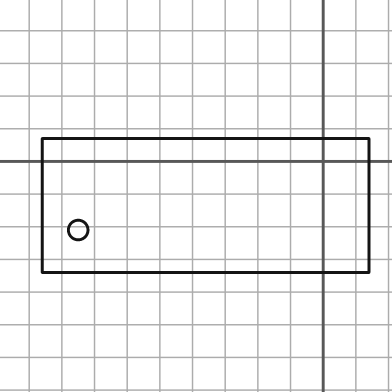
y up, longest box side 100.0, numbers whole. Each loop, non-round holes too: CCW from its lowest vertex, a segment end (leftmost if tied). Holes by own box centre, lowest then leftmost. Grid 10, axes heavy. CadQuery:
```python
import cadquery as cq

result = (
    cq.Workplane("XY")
    .moveTo(-86.0, -34.0)
    .lineTo(14.0, -34.0)
    .lineTo(14.0, 7.0)
    .lineTo(-86.0, 7.0)
    .close()
    .moveTo(-75.0, -21.0)
    .circle(3.0)
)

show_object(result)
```